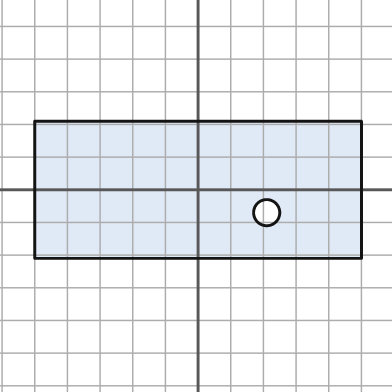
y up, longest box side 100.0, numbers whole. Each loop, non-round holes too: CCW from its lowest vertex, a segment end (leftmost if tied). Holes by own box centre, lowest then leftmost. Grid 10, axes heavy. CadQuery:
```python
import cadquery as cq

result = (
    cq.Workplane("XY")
    .moveTo(-50.0, -21.0)
    .lineTo(50.0, -21.0)
    .lineTo(50.0, 21.0)
    .lineTo(-50.0, 21.0)
    .close()
    .moveTo(21.0, -7.0)
    .circle(4.0)
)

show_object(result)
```